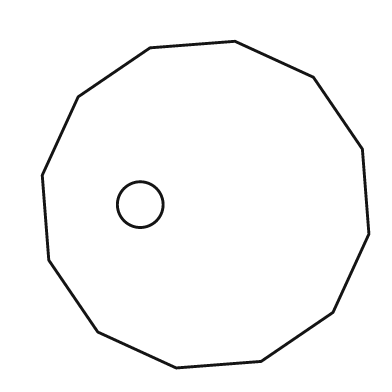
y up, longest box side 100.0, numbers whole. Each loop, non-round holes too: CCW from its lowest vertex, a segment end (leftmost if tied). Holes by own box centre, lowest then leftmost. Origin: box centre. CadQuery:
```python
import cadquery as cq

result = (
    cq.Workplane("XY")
    .moveTo(-9.0, -50.0)
    .lineTo(17.0, -48.0)
    .lineTo(39.0, -33.0)
    .lineTo(50.0, -9.0)
    .lineTo(48.0, 17.0)
    .lineTo(33.0, 39.0)
    .lineTo(9.0, 50.0)
    .lineTo(-17.0, 48.0)
    .lineTo(-39.0, 33.0)
    .lineTo(-50.0, 9.0)
    .lineTo(-48.0, -17.0)
    .lineTo(-33.0, -39.0)
    .close()
    .moveTo(-20.0, 0.0)
    .circle(7.0)
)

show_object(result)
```